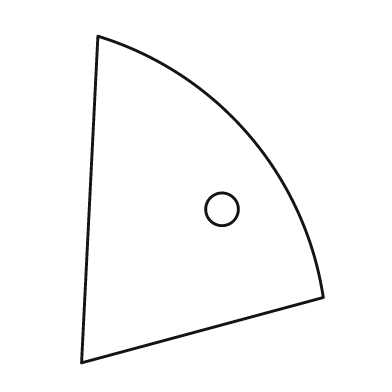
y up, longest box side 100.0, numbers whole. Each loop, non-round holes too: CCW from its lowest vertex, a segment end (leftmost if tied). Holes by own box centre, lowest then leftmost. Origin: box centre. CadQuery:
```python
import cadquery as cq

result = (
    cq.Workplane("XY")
    .moveTo(-37.0, -50.0)
    .lineTo(37.0, -30.0)
    .threePointArc((14.0, 20.0), (-32.0, 50.0))
    .close()
    .moveTo(6.0, -3.0)
    .circle(5.0)
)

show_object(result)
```